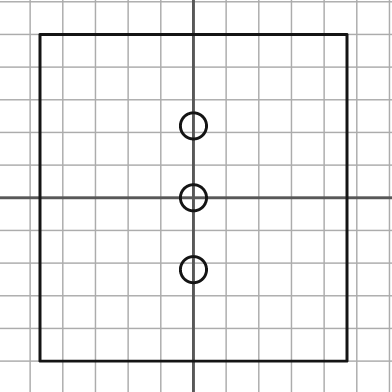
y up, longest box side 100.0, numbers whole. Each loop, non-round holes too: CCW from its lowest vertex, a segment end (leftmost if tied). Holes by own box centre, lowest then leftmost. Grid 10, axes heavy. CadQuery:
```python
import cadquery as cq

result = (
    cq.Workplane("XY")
    .moveTo(-47.0, -50.0)
    .lineTo(47.0, -50.0)
    .lineTo(47.0, 50.0)
    .lineTo(-47.0, 50.0)
    .close()
    .moveTo(0.0, -22.0)
    .circle(4.0)
    .moveTo(0.0, 0.0)
    .circle(4.0)
    .moveTo(0.0, 22.0)
    .circle(4.0)
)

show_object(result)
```